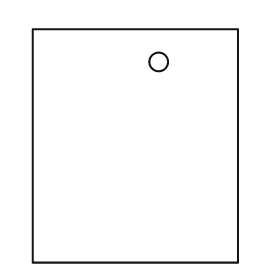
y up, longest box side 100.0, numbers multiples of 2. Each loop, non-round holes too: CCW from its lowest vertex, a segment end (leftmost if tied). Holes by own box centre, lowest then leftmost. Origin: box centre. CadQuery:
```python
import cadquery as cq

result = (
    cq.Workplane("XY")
    .moveTo(-44.0, -50.0)
    .lineTo(44.0, -50.0)
    .lineTo(44.0, 50.0)
    .lineTo(-44.0, 50.0)
    .close()
    .moveTo(10.0, 36.0)
    .circle(4.0)
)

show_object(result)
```